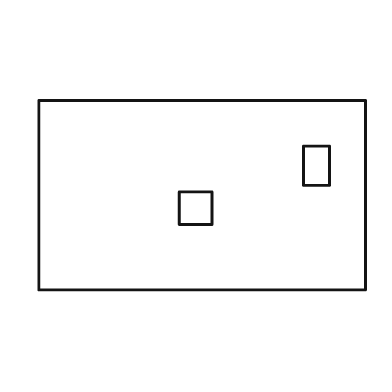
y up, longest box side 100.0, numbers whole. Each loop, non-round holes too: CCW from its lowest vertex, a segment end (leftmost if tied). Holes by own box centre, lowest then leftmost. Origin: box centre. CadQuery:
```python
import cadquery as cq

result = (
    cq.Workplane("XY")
    .moveTo(-50.0, -29.0)
    .lineTo(50.0, -29.0)
    .lineTo(50.0, 29.0)
    .lineTo(-50.0, 29.0)
    .close()
    .moveTo(-7.0, -9.0)
    .lineTo(3.0, -9.0)
    .lineTo(3.0, 1.0)
    .lineTo(-7.0, 1.0)
    .close()
    .moveTo(31.0, 3.0)
    .lineTo(39.0, 3.0)
    .lineTo(39.0, 15.0)
    .lineTo(31.0, 15.0)
    .close()
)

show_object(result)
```